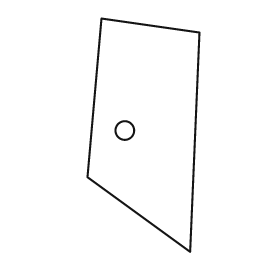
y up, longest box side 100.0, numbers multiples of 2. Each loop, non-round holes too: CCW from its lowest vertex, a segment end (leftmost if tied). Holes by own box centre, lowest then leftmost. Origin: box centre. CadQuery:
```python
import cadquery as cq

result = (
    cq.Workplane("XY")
    .moveTo(20.0, -50.0)
    .lineTo(24.0, 44.0)
    .lineTo(-18.0, 50.0)
    .lineTo(-24.0, -18.0)
    .close()
    .moveTo(-8.0, 2.0)
    .circle(4.0)
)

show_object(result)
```